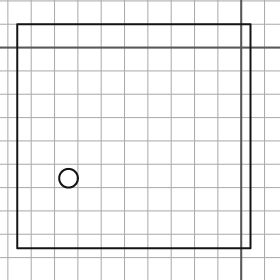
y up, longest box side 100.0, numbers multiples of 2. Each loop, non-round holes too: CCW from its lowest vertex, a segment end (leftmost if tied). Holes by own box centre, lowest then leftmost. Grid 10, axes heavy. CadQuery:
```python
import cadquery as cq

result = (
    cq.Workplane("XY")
    .moveTo(-96.0, -86.0)
    .lineTo(4.0, -86.0)
    .lineTo(4.0, 10.0)
    .lineTo(-96.0, 10.0)
    .close()
    .moveTo(-74.0, -56.0)
    .circle(4.0)
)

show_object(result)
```